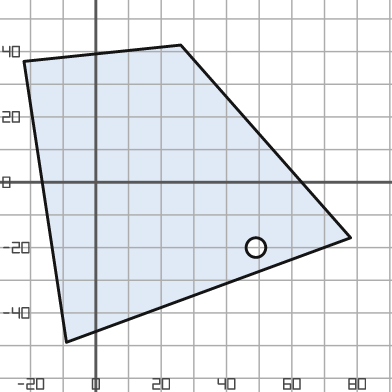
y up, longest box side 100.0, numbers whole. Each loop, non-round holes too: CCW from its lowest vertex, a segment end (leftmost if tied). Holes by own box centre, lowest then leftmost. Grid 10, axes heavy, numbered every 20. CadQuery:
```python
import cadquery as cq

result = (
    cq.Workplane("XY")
    .moveTo(-9.0, -49.0)
    .lineTo(78.0, -17.0)
    .lineTo(26.0, 42.0)
    .lineTo(-22.0, 37.0)
    .close()
    .moveTo(49.0, -20.0)
    .circle(3.0)
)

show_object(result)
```